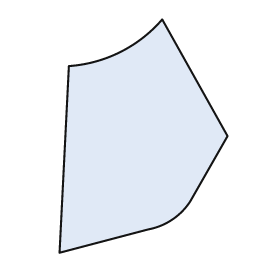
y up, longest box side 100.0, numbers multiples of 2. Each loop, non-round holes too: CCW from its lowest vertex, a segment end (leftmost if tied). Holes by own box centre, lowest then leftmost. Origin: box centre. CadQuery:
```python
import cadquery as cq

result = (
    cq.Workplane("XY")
    .moveTo(-36.0, -50.0)
    .lineTo(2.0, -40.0)
    .threePointArc((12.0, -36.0), (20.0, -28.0))
    .lineTo(36.0, 0.0)
    .lineTo(8.0, 50.0)
    .threePointArc((-10.0, 36.0), (-32.0, 30.0))
    .close()
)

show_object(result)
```